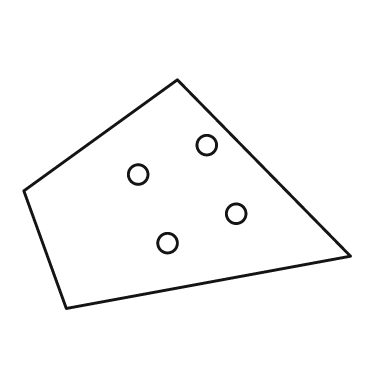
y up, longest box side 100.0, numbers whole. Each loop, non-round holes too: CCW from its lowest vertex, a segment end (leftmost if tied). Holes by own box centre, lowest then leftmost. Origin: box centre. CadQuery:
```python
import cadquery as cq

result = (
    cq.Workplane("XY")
    .moveTo(-37.0, -35.0)
    .lineTo(50.0, -19.0)
    .lineTo(-3.0, 35.0)
    .lineTo(-50.0, 1.0)
    .close()
    .moveTo(-6.0, -15.0)
    .circle(3.0)
    .moveTo(15.0, -6.0)
    .circle(3.0)
    .moveTo(-15.0, 6.0)
    .circle(3.0)
    .moveTo(6.0, 15.0)
    .circle(3.0)
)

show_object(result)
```